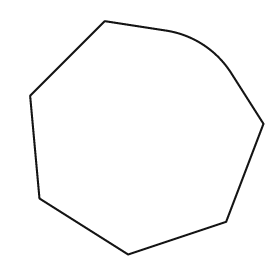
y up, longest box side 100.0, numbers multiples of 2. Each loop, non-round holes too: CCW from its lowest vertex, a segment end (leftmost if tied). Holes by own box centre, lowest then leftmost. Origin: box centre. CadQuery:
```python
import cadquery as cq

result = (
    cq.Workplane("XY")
    .moveTo(-8.0, -50.0)
    .lineTo(34.0, -36.0)
    .lineTo(50.0, 6.0)
    .lineTo(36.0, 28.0)
    .threePointArc((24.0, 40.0), (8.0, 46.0))
    .lineTo(-18.0, 50.0)
    .lineTo(-50.0, 18.0)
    .lineTo(-46.0, -26.0)
    .close()
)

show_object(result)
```